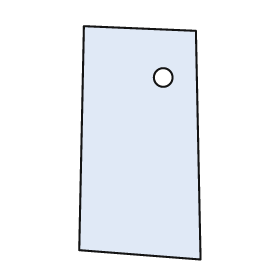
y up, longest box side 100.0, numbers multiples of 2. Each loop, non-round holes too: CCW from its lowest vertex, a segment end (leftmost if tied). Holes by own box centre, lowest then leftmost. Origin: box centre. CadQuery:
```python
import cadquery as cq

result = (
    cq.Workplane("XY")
    .moveTo(26.0, -50.0)
    .lineTo(24.0, 48.0)
    .lineTo(-24.0, 50.0)
    .lineTo(-26.0, -46.0)
    .close()
    .moveTo(10.0, 28.0)
    .circle(4.0)
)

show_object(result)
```